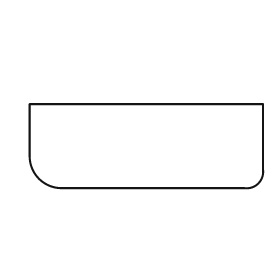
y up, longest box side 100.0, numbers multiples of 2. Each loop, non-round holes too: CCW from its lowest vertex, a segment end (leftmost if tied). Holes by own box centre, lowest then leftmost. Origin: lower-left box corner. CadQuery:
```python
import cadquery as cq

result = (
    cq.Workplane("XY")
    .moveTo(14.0, 0.0)
    .lineTo(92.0, 0.0)
    .threePointArc((98.0, 2.0), (100.0, 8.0))
    .lineTo(100.0, 36.0)
    .lineTo(0.0, 36.0)
    .lineTo(0.0, 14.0)
    .threePointArc((4.0, 4.0), (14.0, 0.0))
    .close()
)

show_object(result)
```